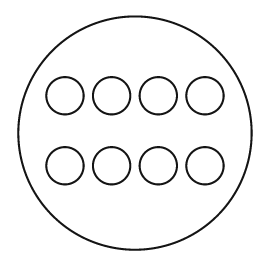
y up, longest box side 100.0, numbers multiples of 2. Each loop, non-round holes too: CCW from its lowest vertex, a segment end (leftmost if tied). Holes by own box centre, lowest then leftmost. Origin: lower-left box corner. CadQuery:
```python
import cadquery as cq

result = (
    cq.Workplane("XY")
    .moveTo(50.0, 50.0)
    .circle(50.0)
    .moveTo(20.0, 36.0)
    .circle(8.0)
    .moveTo(40.0, 36.0)
    .circle(8.0)
    .moveTo(60.0, 36.0)
    .circle(8.0)
    .moveTo(80.0, 36.0)
    .circle(8.0)
    .moveTo(20.0, 66.0)
    .circle(8.0)
    .moveTo(40.0, 66.0)
    .circle(8.0)
    .moveTo(60.0, 66.0)
    .circle(8.0)
    .moveTo(80.0, 66.0)
    .circle(8.0)
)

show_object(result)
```